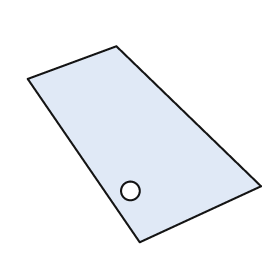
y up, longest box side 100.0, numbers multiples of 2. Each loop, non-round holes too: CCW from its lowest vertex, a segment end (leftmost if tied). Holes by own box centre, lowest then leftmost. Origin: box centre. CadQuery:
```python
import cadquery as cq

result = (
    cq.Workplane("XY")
    .moveTo(-2.0, -42.0)
    .lineTo(50.0, -18.0)
    .lineTo(-12.0, 42.0)
    .lineTo(-50.0, 28.0)
    .close()
    .moveTo(-6.0, -20.0)
    .circle(4.0)
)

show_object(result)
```